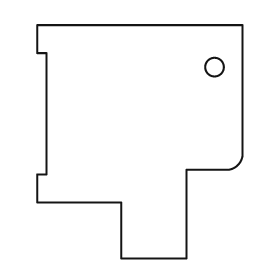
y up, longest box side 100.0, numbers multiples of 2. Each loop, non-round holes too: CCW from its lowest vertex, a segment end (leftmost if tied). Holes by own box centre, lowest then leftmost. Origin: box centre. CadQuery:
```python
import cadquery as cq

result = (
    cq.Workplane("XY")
    .moveTo(-8.0, -50.0)
    .lineTo(20.0, -50.0)
    .lineTo(20.0, -12.0)
    .lineTo(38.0, -12.0)
    .threePointArc((42.0, -10.0), (44.0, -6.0))
    .lineTo(44.0, 50.0)
    .lineTo(-44.0, 50.0)
    .lineTo(-44.0, 38.0)
    .lineTo(-40.0, 38.0)
    .lineTo(-40.0, -14.0)
    .lineTo(-44.0, -14.0)
    .lineTo(-44.0, -26.0)
    .lineTo(-8.0, -26.0)
    .close()
    .moveTo(32.0, 32.0)
    .circle(4.0)
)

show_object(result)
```